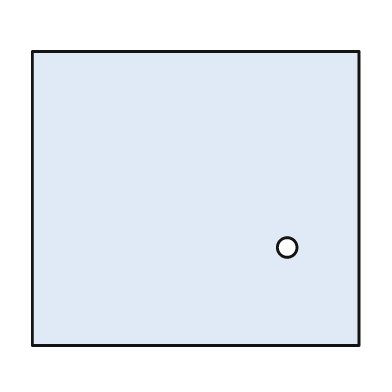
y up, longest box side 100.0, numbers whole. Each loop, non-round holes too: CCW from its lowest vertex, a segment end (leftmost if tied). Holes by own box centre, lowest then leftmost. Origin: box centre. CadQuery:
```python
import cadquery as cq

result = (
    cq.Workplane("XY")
    .moveTo(-50.0, -45.0)
    .lineTo(50.0, -45.0)
    .lineTo(50.0, 45.0)
    .lineTo(-50.0, 45.0)
    .close()
    .moveTo(28.0, -15.0)
    .circle(3.0)
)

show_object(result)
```